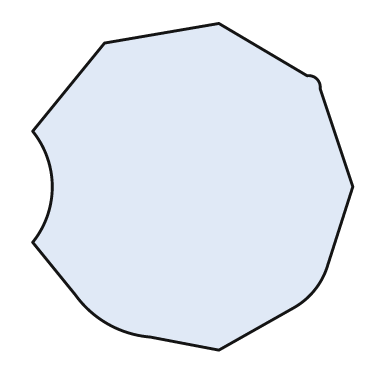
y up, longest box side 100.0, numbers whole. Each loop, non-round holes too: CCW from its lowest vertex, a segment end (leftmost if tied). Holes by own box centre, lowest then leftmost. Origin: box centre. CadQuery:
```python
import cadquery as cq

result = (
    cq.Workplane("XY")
    .moveTo(8.0, -50.0)
    .lineTo(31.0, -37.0)
    .threePointArc((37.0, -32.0), (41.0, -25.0))
    .lineTo(49.0, 0.0)
    .lineTo(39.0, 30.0)
    .threePointArc((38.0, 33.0), (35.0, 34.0))
    .lineTo(8.0, 50.0)
    .lineTo(-27.0, 44.0)
    .lineTo(-49.0, 17.0)
    .threePointArc((-43.0, 0.0), (-49.0, -17.0))
    .lineTo(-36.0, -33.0)
    .threePointArc((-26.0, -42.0), (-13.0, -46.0))
    .close()
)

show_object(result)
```